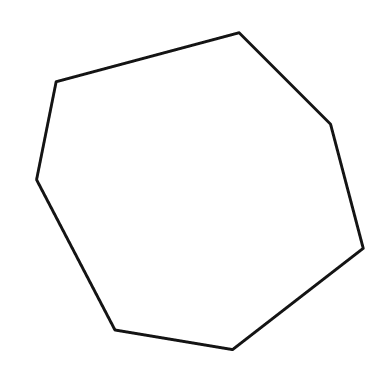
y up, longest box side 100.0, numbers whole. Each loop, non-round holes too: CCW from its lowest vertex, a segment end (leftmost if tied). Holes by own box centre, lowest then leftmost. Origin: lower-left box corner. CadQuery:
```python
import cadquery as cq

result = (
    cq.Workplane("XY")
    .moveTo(60.0, 0.0)
    .lineTo(100.0, 31.0)
    .lineTo(90.0, 69.0)
    .lineTo(62.0, 97.0)
    .lineTo(6.0, 82.0)
    .lineTo(0.0, 52.0)
    .lineTo(24.0, 6.0)
    .close()
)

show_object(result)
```